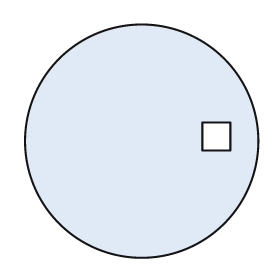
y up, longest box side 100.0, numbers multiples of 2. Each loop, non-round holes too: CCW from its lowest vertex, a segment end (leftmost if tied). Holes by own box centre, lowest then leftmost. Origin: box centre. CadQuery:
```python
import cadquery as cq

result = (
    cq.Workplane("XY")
    .moveTo(0.0, 0.0)
    .circle(50.0)
    .moveTo(26.0, -4.0)
    .lineTo(38.0, -4.0)
    .lineTo(38.0, 8.0)
    .lineTo(26.0, 8.0)
    .close()
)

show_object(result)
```